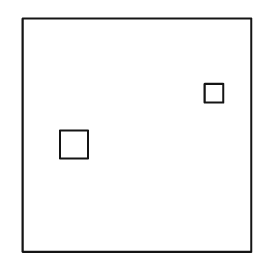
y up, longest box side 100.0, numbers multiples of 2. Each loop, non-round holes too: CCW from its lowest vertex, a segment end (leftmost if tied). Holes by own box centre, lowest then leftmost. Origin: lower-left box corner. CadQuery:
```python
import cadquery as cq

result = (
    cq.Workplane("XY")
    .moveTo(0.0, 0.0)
    .lineTo(98.0, 0.0)
    .lineTo(98.0, 100.0)
    .lineTo(0.0, 100.0)
    .close()
    .moveTo(16.0, 40.0)
    .lineTo(28.0, 40.0)
    .lineTo(28.0, 52.0)
    .lineTo(16.0, 52.0)
    .close()
    .moveTo(78.0, 64.0)
    .lineTo(86.0, 64.0)
    .lineTo(86.0, 72.0)
    .lineTo(78.0, 72.0)
    .close()
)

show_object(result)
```